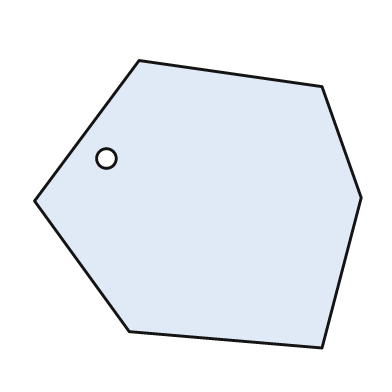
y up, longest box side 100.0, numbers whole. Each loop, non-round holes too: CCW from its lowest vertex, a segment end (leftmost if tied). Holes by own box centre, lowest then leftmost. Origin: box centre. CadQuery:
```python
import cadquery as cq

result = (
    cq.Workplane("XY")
    .moveTo(38.0, -44.0)
    .lineTo(50.0, 2.0)
    .lineTo(38.0, 36.0)
    .lineTo(-18.0, 44.0)
    .lineTo(-50.0, 1.0)
    .lineTo(-21.0, -39.0)
    .close()
    .moveTo(-28.0, 14.0)
    .circle(3.0)
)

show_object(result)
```